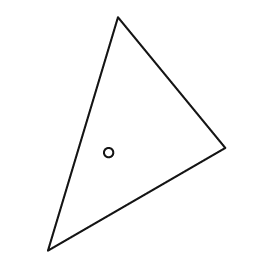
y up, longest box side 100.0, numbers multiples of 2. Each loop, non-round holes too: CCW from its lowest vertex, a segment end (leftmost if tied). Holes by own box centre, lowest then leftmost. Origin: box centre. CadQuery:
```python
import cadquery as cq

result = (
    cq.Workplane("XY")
    .moveTo(-38.0, -50.0)
    .lineTo(38.0, -6.0)
    .lineTo(-8.0, 50.0)
    .close()
    .moveTo(-12.0, -8.0)
    .circle(2.0)
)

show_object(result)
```